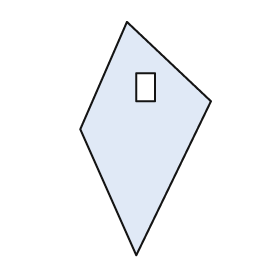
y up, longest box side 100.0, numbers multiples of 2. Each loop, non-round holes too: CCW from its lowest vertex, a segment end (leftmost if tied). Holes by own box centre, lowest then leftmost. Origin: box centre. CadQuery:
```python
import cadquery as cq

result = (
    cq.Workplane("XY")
    .moveTo(-4.0, -50.0)
    .lineTo(28.0, 16.0)
    .lineTo(-8.0, 50.0)
    .lineTo(-28.0, 4.0)
    .close()
    .moveTo(-4.0, 16.0)
    .lineTo(4.0, 16.0)
    .lineTo(4.0, 28.0)
    .lineTo(-4.0, 28.0)
    .close()
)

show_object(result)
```